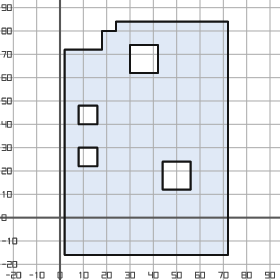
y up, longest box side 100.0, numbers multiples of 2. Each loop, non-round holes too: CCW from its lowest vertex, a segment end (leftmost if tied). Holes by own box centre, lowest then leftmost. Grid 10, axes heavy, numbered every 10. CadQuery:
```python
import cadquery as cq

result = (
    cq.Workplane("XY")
    .moveTo(2.0, -16.0)
    .lineTo(72.0, -16.0)
    .lineTo(72.0, 84.0)
    .lineTo(24.0, 84.0)
    .lineTo(24.0, 80.0)
    .lineTo(18.0, 80.0)
    .lineTo(18.0, 72.0)
    .lineTo(2.0, 72.0)
    .close()
    .moveTo(44.0, 12.0)
    .lineTo(56.0, 12.0)
    .lineTo(56.0, 24.0)
    .lineTo(44.0, 24.0)
    .close()
    .moveTo(8.0, 22.0)
    .lineTo(16.0, 22.0)
    .lineTo(16.0, 30.0)
    .lineTo(8.0, 30.0)
    .close()
    .moveTo(8.0, 40.0)
    .lineTo(16.0, 40.0)
    .lineTo(16.0, 48.0)
    .lineTo(8.0, 48.0)
    .close()
    .moveTo(30.0, 62.0)
    .lineTo(42.0, 62.0)
    .lineTo(42.0, 74.0)
    .lineTo(30.0, 74.0)
    .close()
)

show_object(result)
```